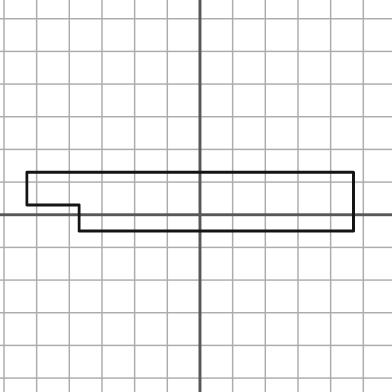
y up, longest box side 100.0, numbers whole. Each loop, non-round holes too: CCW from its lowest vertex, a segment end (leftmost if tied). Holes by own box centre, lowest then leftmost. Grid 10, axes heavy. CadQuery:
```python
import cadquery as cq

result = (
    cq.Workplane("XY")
    .moveTo(-37.0, -5.0)
    .lineTo(47.0, -5.0)
    .lineTo(47.0, 13.0)
    .lineTo(-53.0, 13.0)
    .lineTo(-53.0, 3.0)
    .lineTo(-37.0, 3.0)
    .close()
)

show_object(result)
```